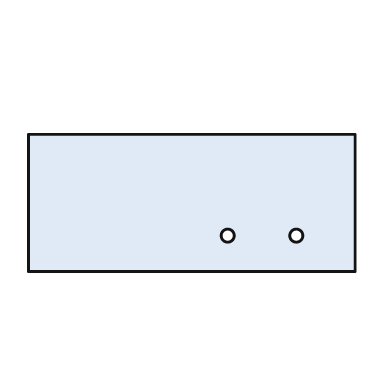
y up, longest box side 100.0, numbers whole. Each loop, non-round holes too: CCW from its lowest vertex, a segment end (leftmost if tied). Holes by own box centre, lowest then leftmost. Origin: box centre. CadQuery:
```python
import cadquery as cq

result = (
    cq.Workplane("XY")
    .moveTo(-50.0, -21.0)
    .lineTo(50.0, -21.0)
    .lineTo(50.0, 21.0)
    .lineTo(-50.0, 21.0)
    .close()
    .moveTo(11.0, -10.0)
    .circle(2.0)
    .moveTo(32.0, -10.0)
    .circle(2.0)
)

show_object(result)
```